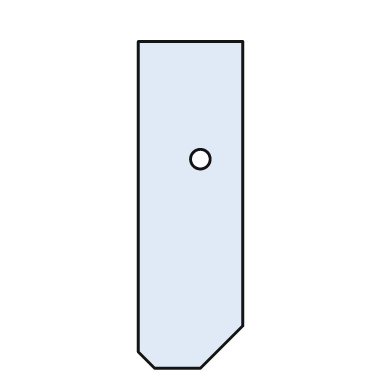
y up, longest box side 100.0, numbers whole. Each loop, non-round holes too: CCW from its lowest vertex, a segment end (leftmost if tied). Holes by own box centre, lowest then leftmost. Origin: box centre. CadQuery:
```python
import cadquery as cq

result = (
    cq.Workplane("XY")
    .moveTo(-11.0, -50.0)
    .lineTo(3.0, -50.0)
    .lineTo(16.0, -37.0)
    .lineTo(16.0, 50.0)
    .lineTo(-16.0, 50.0)
    .lineTo(-16.0, -45.0)
    .close()
    .moveTo(3.0, 14.0)
    .circle(3.0)
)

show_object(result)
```